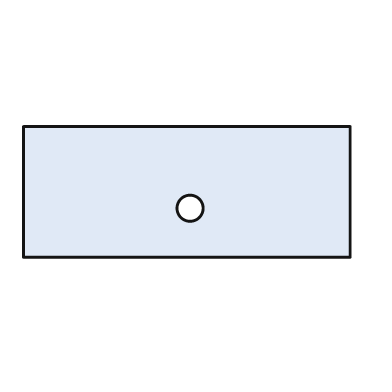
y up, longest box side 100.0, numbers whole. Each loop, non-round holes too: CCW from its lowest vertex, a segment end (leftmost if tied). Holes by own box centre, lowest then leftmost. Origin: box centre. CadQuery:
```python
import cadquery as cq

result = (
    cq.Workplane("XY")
    .moveTo(-50.0, -20.0)
    .lineTo(50.0, -20.0)
    .lineTo(50.0, 20.0)
    .lineTo(-50.0, 20.0)
    .close()
    .moveTo(1.0, -5.0)
    .circle(4.0)
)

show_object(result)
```